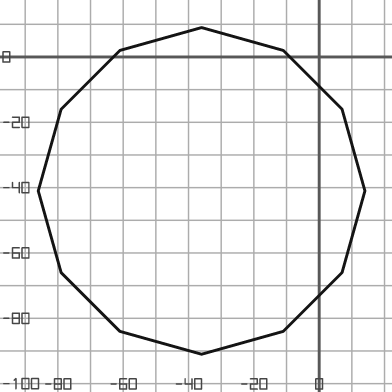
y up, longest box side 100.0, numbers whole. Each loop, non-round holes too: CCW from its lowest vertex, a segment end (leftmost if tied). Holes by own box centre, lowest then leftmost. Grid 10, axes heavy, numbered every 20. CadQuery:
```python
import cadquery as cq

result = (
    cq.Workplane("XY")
    .moveTo(-36.0, -91.0)
    .lineTo(-11.0, -84.0)
    .lineTo(7.0, -66.0)
    .lineTo(14.0, -41.0)
    .lineTo(7.0, -16.0)
    .lineTo(-11.0, 2.0)
    .lineTo(-36.0, 9.0)
    .lineTo(-61.0, 2.0)
    .lineTo(-79.0, -16.0)
    .lineTo(-86.0, -41.0)
    .lineTo(-79.0, -66.0)
    .lineTo(-61.0, -84.0)
    .close()
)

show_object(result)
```